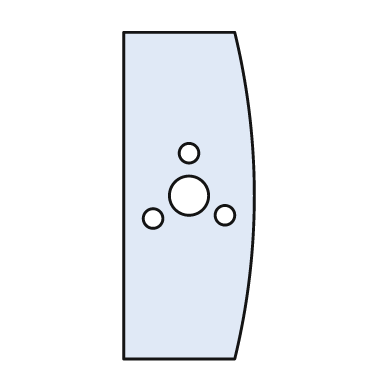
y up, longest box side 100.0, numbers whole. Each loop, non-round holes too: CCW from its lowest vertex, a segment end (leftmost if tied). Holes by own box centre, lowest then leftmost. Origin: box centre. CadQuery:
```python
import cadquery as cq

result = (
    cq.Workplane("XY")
    .moveTo(-20.0, -50.0)
    .lineTo(14.0, -50.0)
    .threePointArc((20.0, 0.0), (14.0, 50.0))
    .lineTo(-20.0, 50.0)
    .close()
    .moveTo(-11.0, -7.0)
    .circle(3.0)
    .moveTo(11.0, -6.0)
    .circle(3.0)
    .moveTo(0.0, 0.0)
    .circle(6.0)
    .moveTo(0.0, 13.0)
    .circle(3.0)
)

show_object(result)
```